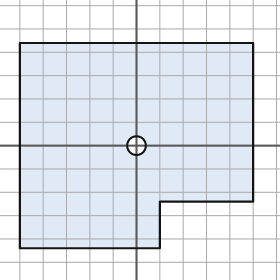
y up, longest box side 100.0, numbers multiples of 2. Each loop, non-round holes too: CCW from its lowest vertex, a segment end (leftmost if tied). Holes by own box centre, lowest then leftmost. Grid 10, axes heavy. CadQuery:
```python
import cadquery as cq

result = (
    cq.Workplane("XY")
    .moveTo(-50.0, -44.0)
    .lineTo(10.0, -44.0)
    .lineTo(10.0, -24.0)
    .lineTo(50.0, -24.0)
    .lineTo(50.0, 44.0)
    .lineTo(-50.0, 44.0)
    .close()
    .moveTo(0.0, 0.0)
    .circle(4.0)
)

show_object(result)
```